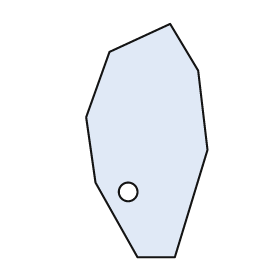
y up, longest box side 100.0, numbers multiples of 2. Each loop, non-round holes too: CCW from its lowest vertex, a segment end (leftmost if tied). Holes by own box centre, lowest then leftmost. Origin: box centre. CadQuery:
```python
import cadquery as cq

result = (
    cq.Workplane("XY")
    .moveTo(-4.0, -50.0)
    .lineTo(12.0, -50.0)
    .lineTo(26.0, -4.0)
    .lineTo(22.0, 30.0)
    .lineTo(10.0, 50.0)
    .lineTo(-16.0, 38.0)
    .lineTo(-26.0, 10.0)
    .lineTo(-22.0, -18.0)
    .close()
    .moveTo(-8.0, -22.0)
    .circle(4.0)
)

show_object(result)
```